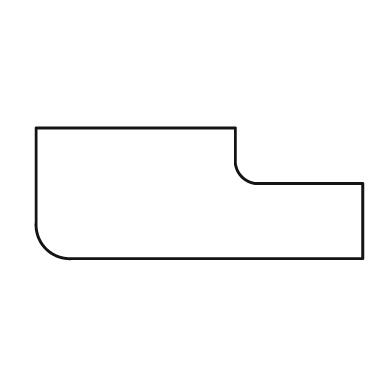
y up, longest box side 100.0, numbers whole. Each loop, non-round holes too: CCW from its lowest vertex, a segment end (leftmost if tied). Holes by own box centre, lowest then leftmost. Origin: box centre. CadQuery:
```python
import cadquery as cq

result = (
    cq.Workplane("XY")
    .moveTo(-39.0, -20.0)
    .lineTo(50.0, -20.0)
    .lineTo(50.0, 3.0)
    .lineTo(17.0, 3.0)
    .threePointArc((13.0, 5.0), (11.0, 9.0))
    .lineTo(11.0, 20.0)
    .lineTo(-50.0, 20.0)
    .lineTo(-50.0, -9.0)
    .threePointArc((-47.0, -17.0), (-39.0, -20.0))
    .close()
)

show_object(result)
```